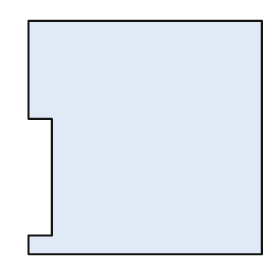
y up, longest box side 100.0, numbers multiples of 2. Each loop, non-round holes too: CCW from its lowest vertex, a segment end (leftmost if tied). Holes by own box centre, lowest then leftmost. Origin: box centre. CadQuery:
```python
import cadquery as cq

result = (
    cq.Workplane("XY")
    .moveTo(-50.0, -50.0)
    .lineTo(50.0, -50.0)
    .lineTo(50.0, 50.0)
    .lineTo(-50.0, 50.0)
    .lineTo(-50.0, 8.0)
    .lineTo(-40.0, 8.0)
    .lineTo(-40.0, -42.0)
    .lineTo(-50.0, -42.0)
    .close()
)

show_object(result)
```